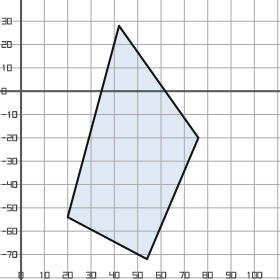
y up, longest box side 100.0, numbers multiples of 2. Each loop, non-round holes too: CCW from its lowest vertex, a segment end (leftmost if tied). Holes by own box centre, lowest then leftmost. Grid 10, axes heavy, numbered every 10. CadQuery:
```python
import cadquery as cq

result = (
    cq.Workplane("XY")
    .moveTo(54.0, -72.0)
    .lineTo(76.0, -20.0)
    .lineTo(42.0, 28.0)
    .lineTo(20.0, -54.0)
    .close()
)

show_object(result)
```